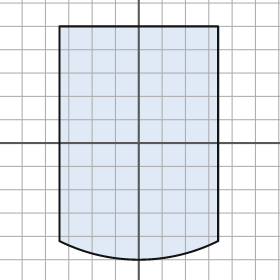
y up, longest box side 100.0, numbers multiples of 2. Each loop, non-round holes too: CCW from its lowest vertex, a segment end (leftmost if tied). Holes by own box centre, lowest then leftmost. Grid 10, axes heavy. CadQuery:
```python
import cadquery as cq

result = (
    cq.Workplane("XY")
    .moveTo(-34.0, -42.0)
    .threePointArc((0.0, -50.0), (34.0, -42.0))
    .lineTo(34.0, 50.0)
    .lineTo(-34.0, 50.0)
    .close()
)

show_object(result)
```